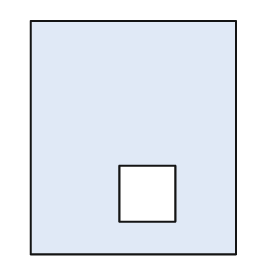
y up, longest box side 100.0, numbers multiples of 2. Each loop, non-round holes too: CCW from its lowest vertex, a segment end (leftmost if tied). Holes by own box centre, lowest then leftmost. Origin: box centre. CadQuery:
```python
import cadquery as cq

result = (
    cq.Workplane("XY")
    .moveTo(-44.0, -50.0)
    .lineTo(44.0, -50.0)
    .lineTo(44.0, 50.0)
    .lineTo(-44.0, 50.0)
    .close()
    .moveTo(-6.0, -36.0)
    .lineTo(18.0, -36.0)
    .lineTo(18.0, -12.0)
    .lineTo(-6.0, -12.0)
    .close()
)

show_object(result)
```